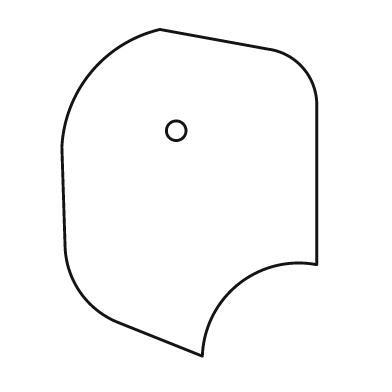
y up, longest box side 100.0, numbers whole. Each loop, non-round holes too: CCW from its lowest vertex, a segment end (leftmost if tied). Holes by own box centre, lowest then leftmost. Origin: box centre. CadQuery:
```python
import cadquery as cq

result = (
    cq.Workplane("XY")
    .moveTo(4.0, -50.0)
    .threePointArc((15.0, -28.0), (39.0, -22.0))
    .lineTo(39.0, 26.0)
    .threePointArc((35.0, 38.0), (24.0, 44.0))
    .lineTo(-9.0, 50.0)
    .threePointArc((-30.0, 37.0), (-39.0, 14.0))
    .lineTo(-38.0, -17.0)
    .threePointArc((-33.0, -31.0), (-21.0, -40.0))
    .close()
    .moveTo(-4.0, 19.0)
    .circle(3.0)
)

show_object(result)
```